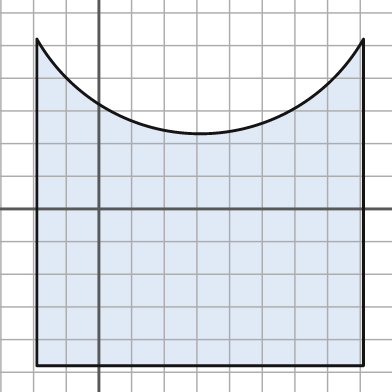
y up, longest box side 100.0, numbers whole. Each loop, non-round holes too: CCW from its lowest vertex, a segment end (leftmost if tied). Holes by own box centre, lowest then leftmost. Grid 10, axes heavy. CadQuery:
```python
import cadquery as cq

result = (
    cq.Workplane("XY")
    .moveTo(-19.0, -48.0)
    .lineTo(81.0, -48.0)
    .lineTo(81.0, 52.0)
    .threePointArc((31.0, 23.0), (-19.0, 52.0))
    .close()
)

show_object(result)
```